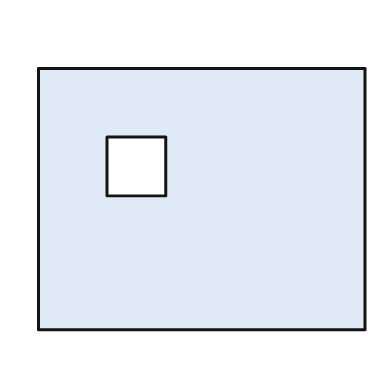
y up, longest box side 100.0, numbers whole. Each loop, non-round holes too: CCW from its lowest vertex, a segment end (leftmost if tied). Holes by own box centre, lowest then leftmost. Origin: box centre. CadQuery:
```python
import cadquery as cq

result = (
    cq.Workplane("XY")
    .moveTo(-50.0, -40.0)
    .lineTo(50.0, -40.0)
    .lineTo(50.0, 40.0)
    .lineTo(-50.0, 40.0)
    .close()
    .moveTo(-29.0, 1.0)
    .lineTo(-11.0, 1.0)
    .lineTo(-11.0, 19.0)
    .lineTo(-29.0, 19.0)
    .close()
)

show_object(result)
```